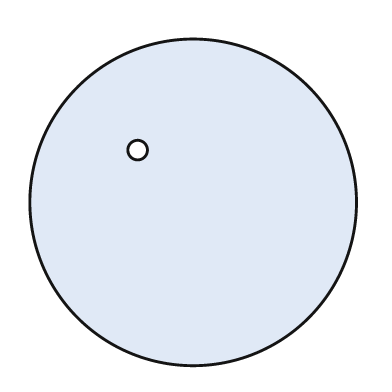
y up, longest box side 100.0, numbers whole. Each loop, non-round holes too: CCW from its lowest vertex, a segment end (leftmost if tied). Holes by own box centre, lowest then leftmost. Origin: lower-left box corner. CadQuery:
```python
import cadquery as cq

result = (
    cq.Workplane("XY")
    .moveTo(50.0, 50.0)
    .circle(50.0)
    .moveTo(33.0, 66.0)
    .circle(3.0)
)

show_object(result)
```